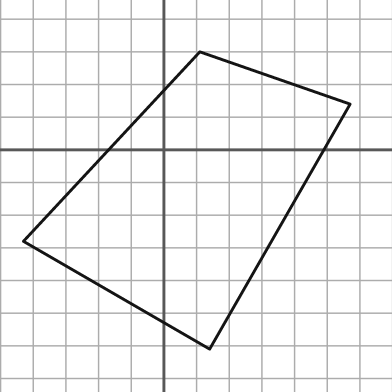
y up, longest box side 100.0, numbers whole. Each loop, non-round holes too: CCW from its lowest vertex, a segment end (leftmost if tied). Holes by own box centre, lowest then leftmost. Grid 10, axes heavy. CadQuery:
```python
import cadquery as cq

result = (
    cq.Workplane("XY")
    .moveTo(14.0, -61.0)
    .lineTo(57.0, 14.0)
    .lineTo(11.0, 30.0)
    .lineTo(-43.0, -28.0)
    .close()
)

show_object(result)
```